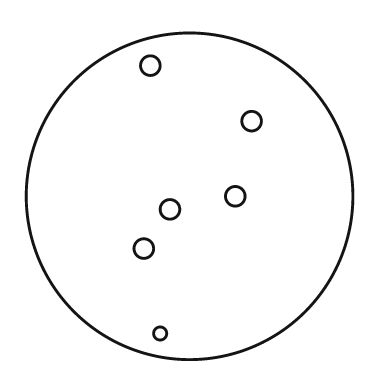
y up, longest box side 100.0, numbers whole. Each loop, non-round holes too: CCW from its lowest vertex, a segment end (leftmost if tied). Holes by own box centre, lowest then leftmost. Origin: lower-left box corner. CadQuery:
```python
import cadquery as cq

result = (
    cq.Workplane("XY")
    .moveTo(50.0, 50.0)
    .circle(50.0)
    .moveTo(41.0, 8.0)
    .circle(2.0)
    .moveTo(36.0, 34.0)
    .circle(3.0)
    .moveTo(44.0, 46.0)
    .circle(3.0)
    .moveTo(64.0, 50.0)
    .circle(3.0)
    .moveTo(69.0, 73.0)
    .circle(3.0)
    .moveTo(38.0, 90.0)
    .circle(3.0)
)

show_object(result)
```